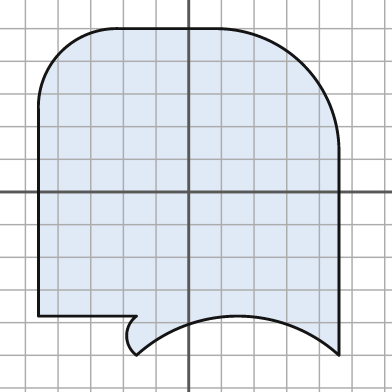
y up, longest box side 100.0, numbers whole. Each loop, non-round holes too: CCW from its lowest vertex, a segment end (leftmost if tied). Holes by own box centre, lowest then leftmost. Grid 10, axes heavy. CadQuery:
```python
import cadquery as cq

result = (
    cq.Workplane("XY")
    .moveTo(-16.0, -50.0)
    .threePointArc((15.0, -38.0), (46.0, -50.0))
    .lineTo(46.0, 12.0)
    .threePointArc((35.0, 39.0), (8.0, 50.0))
    .lineTo(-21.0, 50.0)
    .threePointArc((-39.0, 43.0), (-46.0, 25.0))
    .lineTo(-46.0, -38.0)
    .lineTo(-16.0, -38.0)
    .threePointArc((-19.0, -44.0), (-16.0, -50.0))
    .close()
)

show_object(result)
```